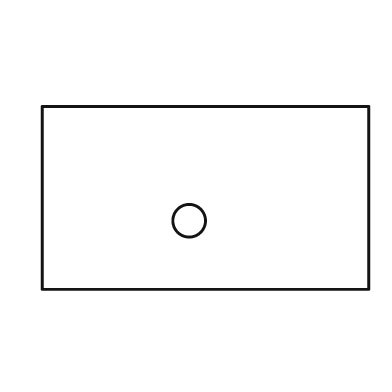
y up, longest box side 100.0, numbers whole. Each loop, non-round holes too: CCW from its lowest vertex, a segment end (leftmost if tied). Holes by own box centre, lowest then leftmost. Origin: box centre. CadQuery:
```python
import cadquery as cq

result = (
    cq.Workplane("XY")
    .moveTo(-50.0, -28.0)
    .lineTo(50.0, -28.0)
    .lineTo(50.0, 28.0)
    .lineTo(-50.0, 28.0)
    .close()
    .moveTo(-5.0, -7.0)
    .circle(5.0)
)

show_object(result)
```